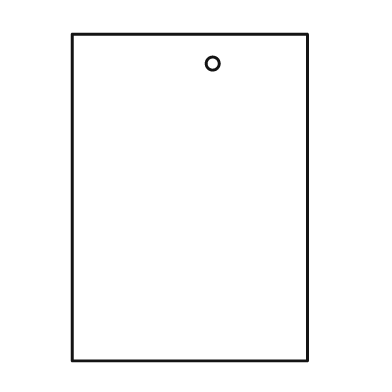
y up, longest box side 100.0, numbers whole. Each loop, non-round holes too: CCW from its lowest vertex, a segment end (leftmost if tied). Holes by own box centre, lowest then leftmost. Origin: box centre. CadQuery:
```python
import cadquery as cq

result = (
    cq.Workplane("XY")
    .moveTo(-36.0, -50.0)
    .lineTo(36.0, -50.0)
    .lineTo(36.0, 50.0)
    .lineTo(-36.0, 50.0)
    .close()
    .moveTo(7.0, 41.0)
    .circle(2.0)
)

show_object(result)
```